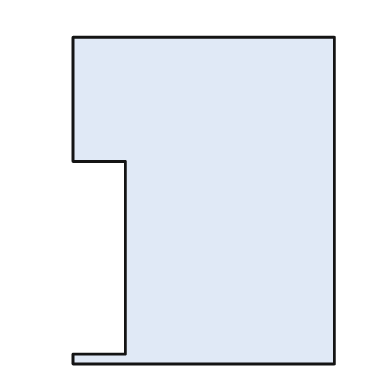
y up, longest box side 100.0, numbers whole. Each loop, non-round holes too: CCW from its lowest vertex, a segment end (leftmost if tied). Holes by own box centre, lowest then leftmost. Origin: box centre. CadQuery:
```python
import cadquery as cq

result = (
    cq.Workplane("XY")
    .moveTo(-40.0, -50.0)
    .lineTo(40.0, -50.0)
    .lineTo(40.0, 50.0)
    .lineTo(-40.0, 50.0)
    .lineTo(-40.0, 12.0)
    .lineTo(-24.0, 12.0)
    .lineTo(-24.0, -47.0)
    .lineTo(-40.0, -47.0)
    .close()
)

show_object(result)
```